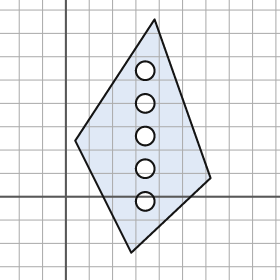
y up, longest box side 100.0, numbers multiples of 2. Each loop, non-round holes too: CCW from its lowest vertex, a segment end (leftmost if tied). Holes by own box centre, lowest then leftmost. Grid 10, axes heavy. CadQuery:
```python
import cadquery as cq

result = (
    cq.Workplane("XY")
    .moveTo(28.0, -24.0)
    .lineTo(62.0, 8.0)
    .lineTo(38.0, 76.0)
    .lineTo(4.0, 24.0)
    .close()
    .moveTo(34.0, -2.0)
    .circle(4.0)
    .moveTo(34.0, 12.0)
    .circle(4.0)
    .moveTo(34.0, 26.0)
    .circle(4.0)
    .moveTo(34.0, 40.0)
    .circle(4.0)
    .moveTo(34.0, 54.0)
    .circle(4.0)
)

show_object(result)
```